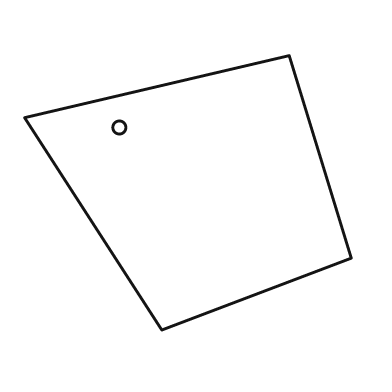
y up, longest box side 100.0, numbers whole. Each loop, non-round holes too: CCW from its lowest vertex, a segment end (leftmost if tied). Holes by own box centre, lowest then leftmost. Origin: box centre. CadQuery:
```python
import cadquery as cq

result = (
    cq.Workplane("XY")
    .moveTo(-8.0, -42.0)
    .lineTo(50.0, -20.0)
    .lineTo(31.0, 42.0)
    .lineTo(-50.0, 23.0)
    .close()
    .moveTo(-21.0, 20.0)
    .circle(2.0)
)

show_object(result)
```